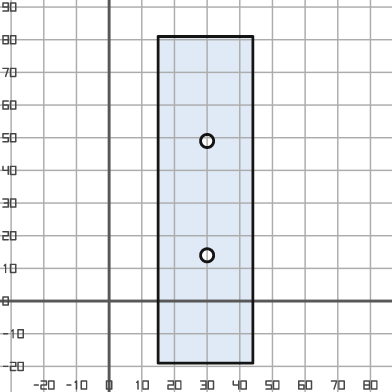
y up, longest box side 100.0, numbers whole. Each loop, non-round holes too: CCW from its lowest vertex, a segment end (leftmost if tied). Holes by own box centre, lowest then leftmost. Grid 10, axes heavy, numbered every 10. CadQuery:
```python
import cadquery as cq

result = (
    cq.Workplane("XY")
    .moveTo(15.0, -19.0)
    .lineTo(44.0, -19.0)
    .lineTo(44.0, 81.0)
    .lineTo(15.0, 81.0)
    .close()
    .moveTo(30.0, 14.0)
    .circle(2.0)
    .moveTo(30.0, 49.0)
    .circle(2.0)
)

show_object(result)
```